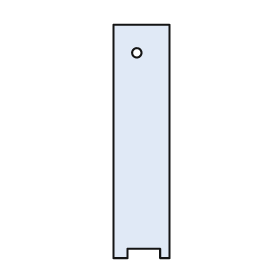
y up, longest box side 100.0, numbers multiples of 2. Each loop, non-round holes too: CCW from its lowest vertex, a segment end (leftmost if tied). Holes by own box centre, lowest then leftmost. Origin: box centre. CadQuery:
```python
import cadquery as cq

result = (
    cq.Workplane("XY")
    .moveTo(-12.0, -50.0)
    .lineTo(-6.0, -50.0)
    .lineTo(-6.0, -46.0)
    .lineTo(8.0, -46.0)
    .lineTo(8.0, -50.0)
    .lineTo(12.0, -50.0)
    .lineTo(12.0, 50.0)
    .lineTo(-12.0, 50.0)
    .close()
    .moveTo(-2.0, 38.0)
    .circle(2.0)
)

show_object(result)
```